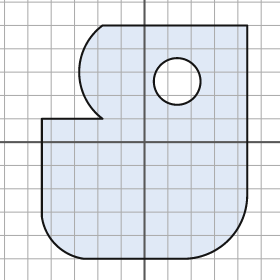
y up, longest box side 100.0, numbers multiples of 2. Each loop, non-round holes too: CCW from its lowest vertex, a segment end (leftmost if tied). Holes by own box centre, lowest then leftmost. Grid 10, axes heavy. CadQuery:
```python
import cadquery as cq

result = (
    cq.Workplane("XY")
    .moveTo(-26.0, -50.0)
    .lineTo(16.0, -50.0)
    .threePointArc((36.0, -42.0), (44.0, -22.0))
    .lineTo(44.0, 50.0)
    .lineTo(-18.0, 50.0)
    .threePointArc((-28.0, 30.0), (-18.0, 10.0))
    .lineTo(-44.0, 10.0)
    .lineTo(-44.0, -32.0)
    .threePointArc((-38.0, -44.0), (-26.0, -50.0))
    .close()
    .moveTo(14.0, 26.0)
    .circle(10.0)
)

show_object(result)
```